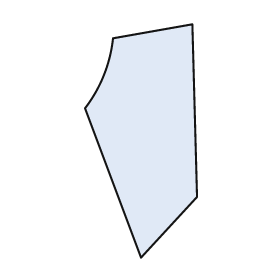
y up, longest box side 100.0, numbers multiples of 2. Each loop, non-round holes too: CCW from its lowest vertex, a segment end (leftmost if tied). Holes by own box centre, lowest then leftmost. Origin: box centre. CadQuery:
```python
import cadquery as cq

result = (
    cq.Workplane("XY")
    .moveTo(0.0, -50.0)
    .lineTo(24.0, -24.0)
    .lineTo(22.0, 50.0)
    .lineTo(-12.0, 44.0)
    .threePointArc((-16.0, 28.0), (-24.0, 14.0))
    .close()
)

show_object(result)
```